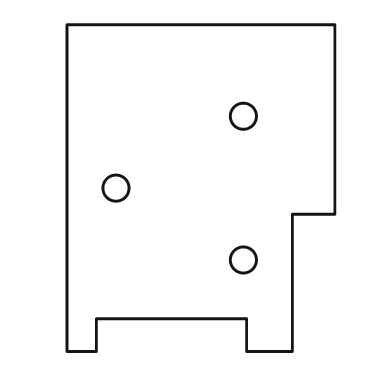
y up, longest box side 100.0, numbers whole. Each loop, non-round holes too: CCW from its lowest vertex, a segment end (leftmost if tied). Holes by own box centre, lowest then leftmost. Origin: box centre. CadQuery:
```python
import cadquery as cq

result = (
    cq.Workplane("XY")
    .moveTo(-41.0, -50.0)
    .lineTo(-32.0, -50.0)
    .lineTo(-32.0, -40.0)
    .lineTo(14.0, -40.0)
    .lineTo(14.0, -50.0)
    .lineTo(28.0, -50.0)
    .lineTo(28.0, -8.0)
    .lineTo(41.0, -8.0)
    .lineTo(41.0, 50.0)
    .lineTo(-41.0, 50.0)
    .close()
    .moveTo(13.0, -22.0)
    .circle(4.0)
    .moveTo(-26.0, 0.0)
    .circle(4.0)
    .moveTo(13.0, 22.0)
    .circle(4.0)
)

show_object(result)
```